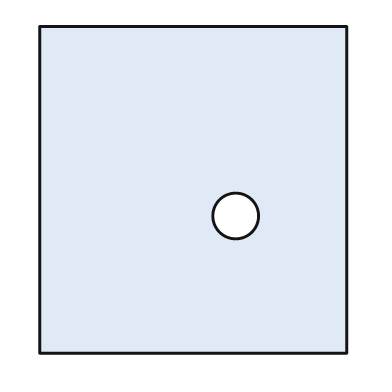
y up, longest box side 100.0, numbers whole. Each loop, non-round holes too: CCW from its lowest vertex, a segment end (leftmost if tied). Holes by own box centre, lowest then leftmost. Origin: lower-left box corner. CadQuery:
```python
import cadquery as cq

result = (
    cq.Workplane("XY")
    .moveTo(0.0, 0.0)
    .lineTo(94.0, 0.0)
    .lineTo(94.0, 100.0)
    .lineTo(0.0, 100.0)
    .close()
    .moveTo(60.0, 42.0)
    .circle(7.0)
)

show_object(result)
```